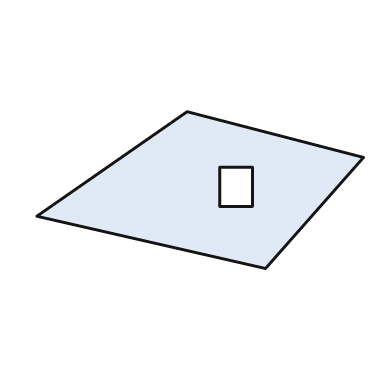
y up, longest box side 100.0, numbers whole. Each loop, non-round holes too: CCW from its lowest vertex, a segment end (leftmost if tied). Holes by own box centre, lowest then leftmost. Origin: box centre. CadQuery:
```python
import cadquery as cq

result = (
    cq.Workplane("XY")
    .moveTo(20.0, -24.0)
    .lineTo(50.0, 10.0)
    .lineTo(-4.0, 24.0)
    .lineTo(-50.0, -8.0)
    .close()
    .moveTo(6.0, -5.0)
    .lineTo(16.0, -5.0)
    .lineTo(16.0, 7.0)
    .lineTo(6.0, 7.0)
    .close()
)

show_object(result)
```